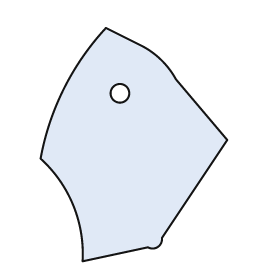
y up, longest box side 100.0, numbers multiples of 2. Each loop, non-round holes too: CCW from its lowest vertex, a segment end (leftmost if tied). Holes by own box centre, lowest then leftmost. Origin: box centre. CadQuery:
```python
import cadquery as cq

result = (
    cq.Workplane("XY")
    .moveTo(-22.0, -50.0)
    .lineTo(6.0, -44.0)
    .threePointArc((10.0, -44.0), (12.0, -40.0))
    .lineTo(40.0, 2.0)
    .lineTo(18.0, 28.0)
    .threePointArc((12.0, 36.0), (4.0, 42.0))
    .lineTo(-12.0, 50.0)
    .threePointArc((-30.0, 24.0), (-40.0, -6.0))
    .threePointArc((-26.0, -26.0), (-22.0, -50.0))
    .close()
    .moveTo(-6.0, 22.0)
    .circle(4.0)
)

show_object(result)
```